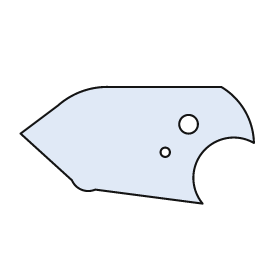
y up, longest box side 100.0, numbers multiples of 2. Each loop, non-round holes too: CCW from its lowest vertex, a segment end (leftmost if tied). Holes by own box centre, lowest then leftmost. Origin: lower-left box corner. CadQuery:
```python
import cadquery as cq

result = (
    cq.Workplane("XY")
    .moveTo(78.0, 0.0)
    .threePointArc((78.0, 22.0), (100.0, 26.0))
    .threePointArc((96.0, 40.0), (86.0, 50.0))
    .lineTo(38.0, 50.0)
    .threePointArc((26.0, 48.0), (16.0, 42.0))
    .lineTo(0.0, 30.0)
    .lineTo(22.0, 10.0)
    .threePointArc((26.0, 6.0), (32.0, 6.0))
    .close()
    .moveTo(62.0, 22.0)
    .circle(2.0)
    .moveTo(72.0, 34.0)
    .circle(4.0)
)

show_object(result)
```